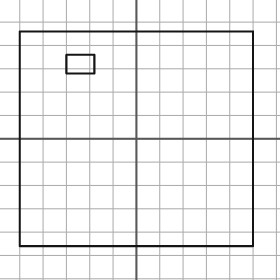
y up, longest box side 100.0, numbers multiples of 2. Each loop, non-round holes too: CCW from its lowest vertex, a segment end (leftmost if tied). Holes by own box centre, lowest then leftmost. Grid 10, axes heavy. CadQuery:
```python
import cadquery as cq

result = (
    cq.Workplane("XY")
    .moveTo(-50.0, -46.0)
    .lineTo(50.0, -46.0)
    .lineTo(50.0, 46.0)
    .lineTo(-50.0, 46.0)
    .close()
    .moveTo(-30.0, 28.0)
    .lineTo(-18.0, 28.0)
    .lineTo(-18.0, 36.0)
    .lineTo(-30.0, 36.0)
    .close()
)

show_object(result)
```